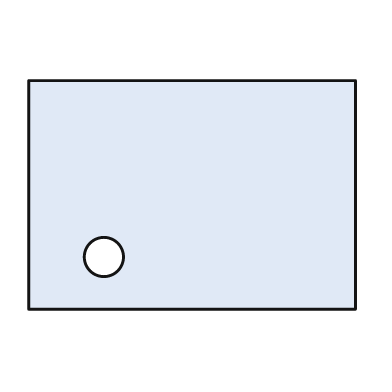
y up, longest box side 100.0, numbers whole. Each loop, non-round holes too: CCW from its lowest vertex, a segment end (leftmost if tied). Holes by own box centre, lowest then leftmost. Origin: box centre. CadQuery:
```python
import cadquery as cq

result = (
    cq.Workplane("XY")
    .moveTo(-50.0, -35.0)
    .lineTo(50.0, -35.0)
    .lineTo(50.0, 35.0)
    .lineTo(-50.0, 35.0)
    .close()
    .moveTo(-27.0, -19.0)
    .circle(6.0)
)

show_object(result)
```